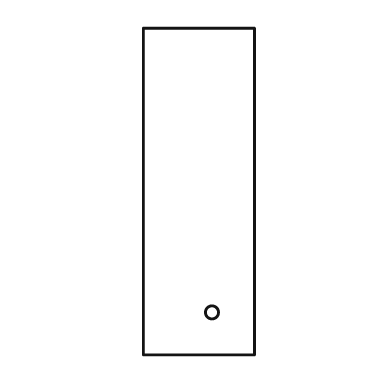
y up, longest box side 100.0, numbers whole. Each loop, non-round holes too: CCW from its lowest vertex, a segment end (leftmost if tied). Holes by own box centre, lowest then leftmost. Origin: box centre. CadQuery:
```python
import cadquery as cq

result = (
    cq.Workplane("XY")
    .moveTo(-17.0, -50.0)
    .lineTo(17.0, -50.0)
    .lineTo(17.0, 50.0)
    .lineTo(-17.0, 50.0)
    .close()
    .moveTo(4.0, -37.0)
    .circle(2.0)
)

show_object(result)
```